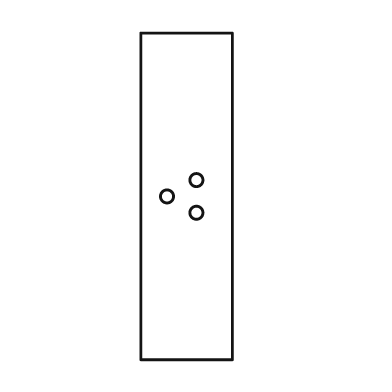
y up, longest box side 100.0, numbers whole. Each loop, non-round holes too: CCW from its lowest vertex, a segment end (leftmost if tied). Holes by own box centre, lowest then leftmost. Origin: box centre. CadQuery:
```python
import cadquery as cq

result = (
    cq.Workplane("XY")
    .moveTo(-14.0, -50.0)
    .lineTo(14.0, -50.0)
    .lineTo(14.0, 50.0)
    .lineTo(-14.0, 50.0)
    .close()
    .moveTo(3.0, -5.0)
    .circle(2.0)
    .moveTo(-6.0, 0.0)
    .circle(2.0)
    .moveTo(3.0, 5.0)
    .circle(2.0)
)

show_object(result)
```